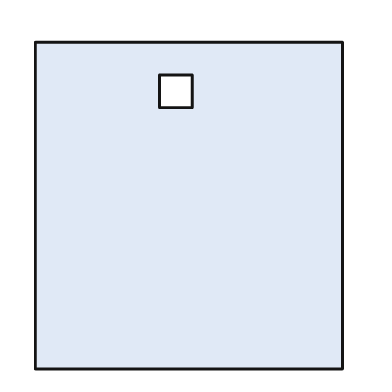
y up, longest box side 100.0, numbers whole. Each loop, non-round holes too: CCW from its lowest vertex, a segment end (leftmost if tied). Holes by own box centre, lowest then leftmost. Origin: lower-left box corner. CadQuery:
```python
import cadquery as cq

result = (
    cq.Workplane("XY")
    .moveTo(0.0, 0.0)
    .lineTo(94.0, 0.0)
    .lineTo(94.0, 100.0)
    .lineTo(0.0, 100.0)
    .close()
    .moveTo(38.0, 80.0)
    .lineTo(48.0, 80.0)
    .lineTo(48.0, 90.0)
    .lineTo(38.0, 90.0)
    .close()
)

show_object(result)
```